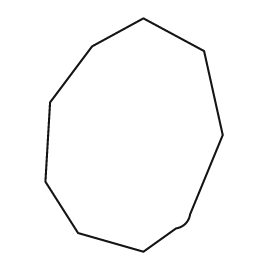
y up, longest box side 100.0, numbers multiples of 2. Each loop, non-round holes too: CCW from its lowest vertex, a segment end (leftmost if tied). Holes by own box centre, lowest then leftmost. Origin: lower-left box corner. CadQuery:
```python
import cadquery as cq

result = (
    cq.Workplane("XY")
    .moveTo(42.0, 0.0)
    .lineTo(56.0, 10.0)
    .threePointArc((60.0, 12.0), (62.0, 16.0))
    .lineTo(76.0, 50.0)
    .lineTo(68.0, 86.0)
    .lineTo(42.0, 100.0)
    .lineTo(20.0, 88.0)
    .lineTo(2.0, 64.0)
    .lineTo(0.0, 30.0)
    .lineTo(14.0, 8.0)
    .close()
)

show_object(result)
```